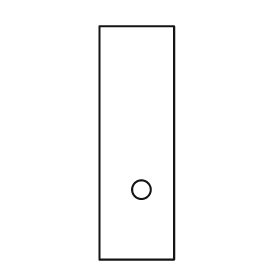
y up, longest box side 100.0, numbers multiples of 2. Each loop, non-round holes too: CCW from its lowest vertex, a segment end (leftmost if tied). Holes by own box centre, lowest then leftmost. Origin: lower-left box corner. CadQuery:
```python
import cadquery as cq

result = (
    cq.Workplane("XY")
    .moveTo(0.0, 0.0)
    .lineTo(32.0, 0.0)
    .lineTo(32.0, 100.0)
    .lineTo(0.0, 100.0)
    .close()
    .moveTo(18.0, 30.0)
    .circle(4.0)
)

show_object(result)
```